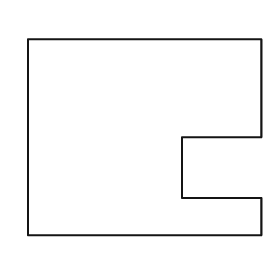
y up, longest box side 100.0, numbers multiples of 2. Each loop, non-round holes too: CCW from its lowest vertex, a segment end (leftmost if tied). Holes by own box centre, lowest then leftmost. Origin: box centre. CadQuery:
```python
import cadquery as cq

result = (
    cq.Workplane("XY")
    .moveTo(-50.0, -42.0)
    .lineTo(50.0, -42.0)
    .lineTo(50.0, -26.0)
    .lineTo(16.0, -26.0)
    .lineTo(16.0, 0.0)
    .lineTo(50.0, 0.0)
    .lineTo(50.0, 42.0)
    .lineTo(-50.0, 42.0)
    .close()
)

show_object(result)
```